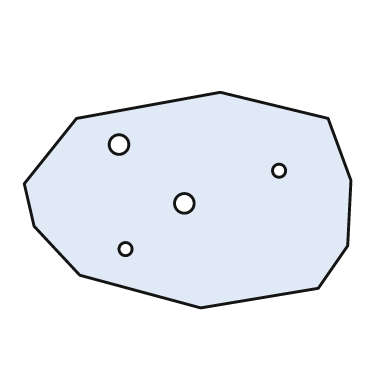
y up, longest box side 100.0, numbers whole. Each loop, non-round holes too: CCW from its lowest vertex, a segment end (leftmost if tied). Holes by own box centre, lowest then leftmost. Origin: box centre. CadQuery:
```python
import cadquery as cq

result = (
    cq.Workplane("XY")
    .moveTo(4.0, -33.0)
    .lineTo(40.0, -27.0)
    .lineTo(49.0, -14.0)
    .lineTo(50.0, 6.0)
    .lineTo(43.0, 25.0)
    .lineTo(10.0, 33.0)
    .lineTo(-34.0, 25.0)
    .lineTo(-50.0, 5.0)
    .lineTo(-47.0, -8.0)
    .lineTo(-33.0, -23.0)
    .close()
    .moveTo(-19.0, -15.0)
    .circle(2.0)
    .moveTo(-1.0, -1.0)
    .circle(3.0)
    .moveTo(28.0, 9.0)
    .circle(2.0)
    .moveTo(-21.0, 17.0)
    .circle(3.0)
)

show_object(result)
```